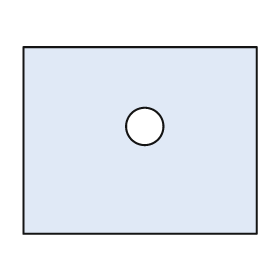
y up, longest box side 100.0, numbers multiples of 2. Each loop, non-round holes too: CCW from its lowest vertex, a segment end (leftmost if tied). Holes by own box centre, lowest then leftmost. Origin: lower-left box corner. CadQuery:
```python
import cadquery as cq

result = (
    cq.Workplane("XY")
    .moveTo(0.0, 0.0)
    .lineTo(100.0, 0.0)
    .lineTo(100.0, 80.0)
    .lineTo(0.0, 80.0)
    .close()
    .moveTo(52.0, 46.0)
    .circle(8.0)
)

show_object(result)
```